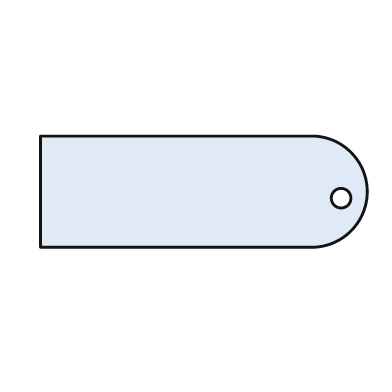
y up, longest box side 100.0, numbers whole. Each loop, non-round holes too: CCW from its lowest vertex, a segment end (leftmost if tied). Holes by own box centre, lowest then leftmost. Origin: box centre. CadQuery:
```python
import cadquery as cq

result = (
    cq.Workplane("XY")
    .moveTo(-50.0, -17.0)
    .lineTo(34.0, -17.0)
    .threePointArc((50.0, 0.0), (34.0, 17.0))
    .lineTo(-50.0, 17.0)
    .close()
    .moveTo(42.0, -2.0)
    .circle(3.0)
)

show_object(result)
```